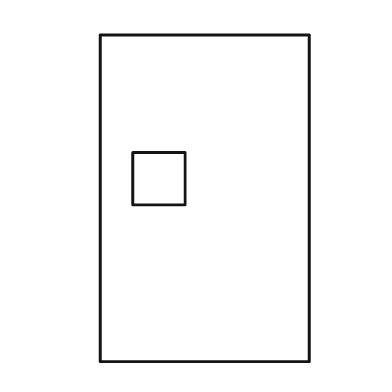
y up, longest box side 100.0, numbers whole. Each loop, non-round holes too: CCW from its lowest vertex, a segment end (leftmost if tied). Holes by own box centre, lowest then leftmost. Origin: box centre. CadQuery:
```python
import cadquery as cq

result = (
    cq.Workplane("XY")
    .moveTo(-32.0, -50.0)
    .lineTo(32.0, -50.0)
    .lineTo(32.0, 50.0)
    .lineTo(-32.0, 50.0)
    .close()
    .moveTo(-22.0, -2.0)
    .lineTo(-6.0, -2.0)
    .lineTo(-6.0, 14.0)
    .lineTo(-22.0, 14.0)
    .close()
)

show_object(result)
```